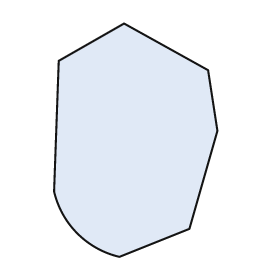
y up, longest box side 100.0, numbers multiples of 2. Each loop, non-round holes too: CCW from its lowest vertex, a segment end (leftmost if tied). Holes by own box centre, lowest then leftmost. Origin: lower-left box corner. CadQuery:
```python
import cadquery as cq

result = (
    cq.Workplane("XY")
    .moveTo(28.0, 0.0)
    .lineTo(58.0, 12.0)
    .lineTo(70.0, 54.0)
    .lineTo(66.0, 80.0)
    .lineTo(30.0, 100.0)
    .lineTo(2.0, 84.0)
    .lineTo(0.0, 28.0)
    .threePointArc((10.0, 10.0), (28.0, 0.0))
    .close()
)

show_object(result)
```